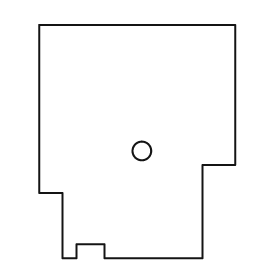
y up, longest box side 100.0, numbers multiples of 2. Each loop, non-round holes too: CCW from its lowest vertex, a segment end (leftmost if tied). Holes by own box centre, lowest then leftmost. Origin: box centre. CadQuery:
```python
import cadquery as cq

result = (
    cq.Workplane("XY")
    .moveTo(-32.0, -50.0)
    .lineTo(-26.0, -50.0)
    .lineTo(-26.0, -44.0)
    .lineTo(-14.0, -44.0)
    .lineTo(-14.0, -50.0)
    .lineTo(28.0, -50.0)
    .lineTo(28.0, -10.0)
    .lineTo(42.0, -10.0)
    .lineTo(42.0, 50.0)
    .lineTo(-42.0, 50.0)
    .lineTo(-42.0, -22.0)
    .lineTo(-32.0, -22.0)
    .close()
    .moveTo(2.0, -4.0)
    .circle(4.0)
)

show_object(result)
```